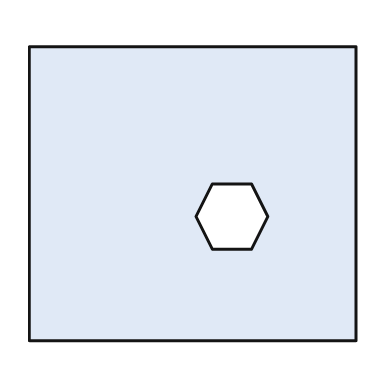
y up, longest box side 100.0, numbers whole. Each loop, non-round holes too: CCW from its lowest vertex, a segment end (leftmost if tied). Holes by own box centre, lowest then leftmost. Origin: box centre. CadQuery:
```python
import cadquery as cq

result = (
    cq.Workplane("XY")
    .moveTo(-50.0, -45.0)
    .lineTo(50.0, -45.0)
    .lineTo(50.0, 45.0)
    .lineTo(-50.0, 45.0)
    .close()
    .moveTo(6.0, -17.0)
    .lineTo(18.0, -17.0)
    .lineTo(23.0, -7.0)
    .lineTo(18.0, 3.0)
    .lineTo(6.0, 3.0)
    .lineTo(1.0, -7.0)
    .close()
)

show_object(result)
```